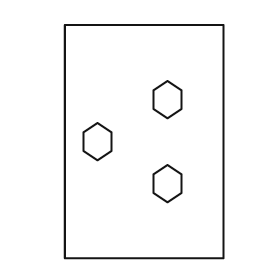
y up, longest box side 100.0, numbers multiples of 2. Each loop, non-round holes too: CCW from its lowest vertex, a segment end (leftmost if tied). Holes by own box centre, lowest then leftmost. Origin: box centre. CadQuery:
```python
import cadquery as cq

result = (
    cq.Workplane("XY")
    .moveTo(-34.0, -50.0)
    .lineTo(34.0, -50.0)
    .lineTo(34.0, 50.0)
    .lineTo(-34.0, 50.0)
    .close()
    .moveTo(10.0, -26.0)
    .lineTo(16.0, -22.0)
    .lineTo(16.0, -14.0)
    .lineTo(10.0, -10.0)
    .lineTo(4.0, -14.0)
    .lineTo(4.0, -22.0)
    .close()
    .moveTo(-20.0, -8.0)
    .lineTo(-14.0, -4.0)
    .lineTo(-14.0, 4.0)
    .lineTo(-20.0, 8.0)
    .lineTo(-26.0, 4.0)
    .lineTo(-26.0, -4.0)
    .close()
    .moveTo(10.0, 10.0)
    .lineTo(16.0, 14.0)
    .lineTo(16.0, 22.0)
    .lineTo(10.0, 26.0)
    .lineTo(4.0, 22.0)
    .lineTo(4.0, 14.0)
    .close()
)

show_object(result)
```